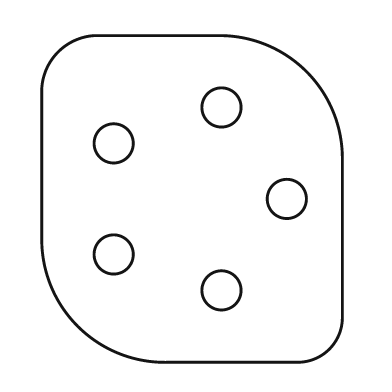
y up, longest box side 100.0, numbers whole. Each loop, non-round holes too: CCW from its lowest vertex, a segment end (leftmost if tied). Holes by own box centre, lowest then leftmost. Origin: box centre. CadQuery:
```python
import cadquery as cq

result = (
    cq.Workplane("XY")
    .moveTo(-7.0, -50.0)
    .lineTo(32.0, -50.0)
    .threePointArc((42.0, -46.0), (46.0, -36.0))
    .lineTo(46.0, 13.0)
    .threePointArc((35.0, 39.0), (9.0, 50.0))
    .lineTo(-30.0, 50.0)
    .threePointArc((-41.0, 45.0), (-46.0, 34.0))
    .lineTo(-46.0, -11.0)
    .threePointArc((-35.0, -39.0), (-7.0, -50.0))
    .close()
    .moveTo(9.0, -28.0)
    .circle(6.0)
    .moveTo(-24.0, -17.0)
    .circle(6.0)
    .moveTo(29.0, 0.0)
    .circle(6.0)
    .moveTo(-24.0, 17.0)
    .circle(6.0)
    .moveTo(9.0, 28.0)
    .circle(6.0)
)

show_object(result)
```